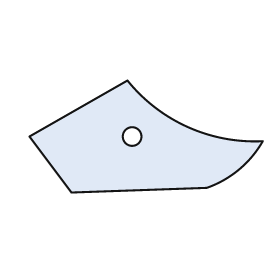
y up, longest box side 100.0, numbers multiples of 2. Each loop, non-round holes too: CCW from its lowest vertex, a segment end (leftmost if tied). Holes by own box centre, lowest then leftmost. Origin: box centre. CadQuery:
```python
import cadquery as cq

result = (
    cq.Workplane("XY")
    .moveTo(-32.0, -24.0)
    .lineTo(26.0, -22.0)
    .threePointArc((40.0, -14.0), (50.0, -2.0))
    .threePointArc((18.0, 4.0), (-8.0, 24.0))
    .lineTo(-50.0, 0.0)
    .close()
    .moveTo(-6.0, 0.0)
    .circle(4.0)
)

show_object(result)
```